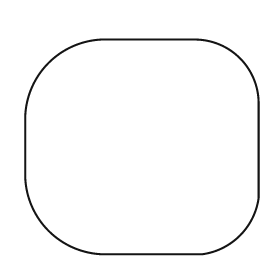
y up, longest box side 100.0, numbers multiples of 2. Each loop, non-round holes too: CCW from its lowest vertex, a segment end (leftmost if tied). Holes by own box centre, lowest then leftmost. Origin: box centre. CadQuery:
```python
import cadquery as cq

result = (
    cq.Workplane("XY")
    .moveTo(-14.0, -46.0)
    .lineTo(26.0, -46.0)
    .threePointArc((42.0, -38.0), (50.0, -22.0))
    .lineTo(50.0, 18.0)
    .threePointArc((42.0, 38.0), (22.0, 46.0))
    .lineTo(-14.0, 46.0)
    .threePointArc((-40.0, 36.0), (-50.0, 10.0))
    .lineTo(-50.0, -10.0)
    .threePointArc((-40.0, -36.0), (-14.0, -46.0))
    .close()
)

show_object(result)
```